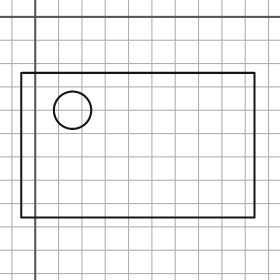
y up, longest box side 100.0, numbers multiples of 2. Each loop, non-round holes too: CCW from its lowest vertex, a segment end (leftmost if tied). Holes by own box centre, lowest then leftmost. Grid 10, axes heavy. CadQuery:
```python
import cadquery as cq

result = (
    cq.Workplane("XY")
    .moveTo(-6.0, -86.0)
    .lineTo(94.0, -86.0)
    .lineTo(94.0, -24.0)
    .lineTo(-6.0, -24.0)
    .close()
    .moveTo(16.0, -40.0)
    .circle(8.0)
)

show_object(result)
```